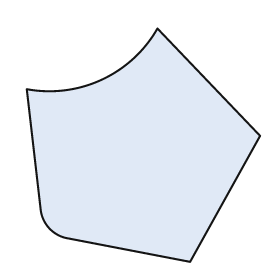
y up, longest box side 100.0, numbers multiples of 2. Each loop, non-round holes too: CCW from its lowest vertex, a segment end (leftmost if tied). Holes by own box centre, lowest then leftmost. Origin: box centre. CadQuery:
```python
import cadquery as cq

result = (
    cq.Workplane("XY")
    .moveTo(20.0, -50.0)
    .lineTo(50.0, 4.0)
    .lineTo(6.0, 50.0)
    .threePointArc((-18.0, 28.0), (-50.0, 24.0))
    .lineTo(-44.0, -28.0)
    .threePointArc((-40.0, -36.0), (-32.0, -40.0))
    .close()
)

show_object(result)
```